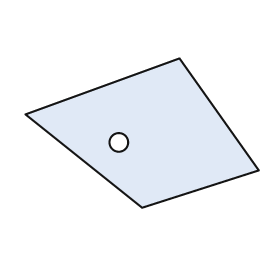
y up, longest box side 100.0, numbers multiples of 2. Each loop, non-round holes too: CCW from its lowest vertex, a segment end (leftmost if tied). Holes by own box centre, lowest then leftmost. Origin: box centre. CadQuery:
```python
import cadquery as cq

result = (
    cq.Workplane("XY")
    .moveTo(0.0, -32.0)
    .lineTo(50.0, -16.0)
    .lineTo(16.0, 32.0)
    .lineTo(-50.0, 8.0)
    .close()
    .moveTo(-10.0, -4.0)
    .circle(4.0)
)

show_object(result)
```